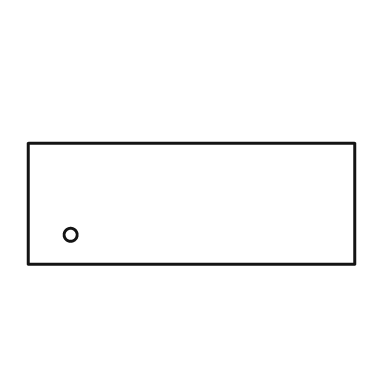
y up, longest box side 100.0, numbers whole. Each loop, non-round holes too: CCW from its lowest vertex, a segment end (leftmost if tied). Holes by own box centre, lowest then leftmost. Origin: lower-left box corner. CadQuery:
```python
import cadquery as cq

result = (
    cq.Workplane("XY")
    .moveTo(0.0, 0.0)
    .lineTo(100.0, 0.0)
    .lineTo(100.0, 37.0)
    .lineTo(0.0, 37.0)
    .close()
    .moveTo(13.0, 9.0)
    .circle(2.0)
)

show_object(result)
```